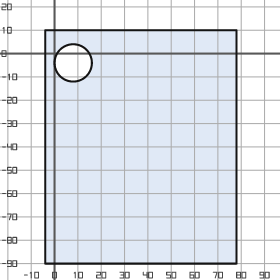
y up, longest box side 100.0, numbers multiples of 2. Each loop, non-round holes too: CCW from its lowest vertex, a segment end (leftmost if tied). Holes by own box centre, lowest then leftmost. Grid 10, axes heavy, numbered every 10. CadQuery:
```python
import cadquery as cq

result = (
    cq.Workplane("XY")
    .moveTo(-4.0, -90.0)
    .lineTo(78.0, -90.0)
    .lineTo(78.0, 10.0)
    .lineTo(-4.0, 10.0)
    .close()
    .moveTo(8.0, -4.0)
    .circle(8.0)
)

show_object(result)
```